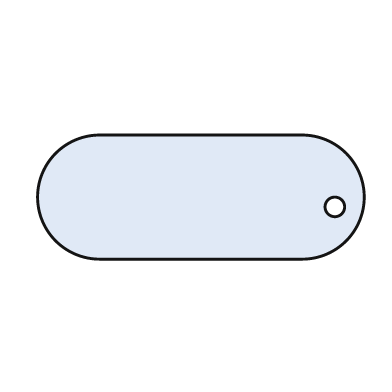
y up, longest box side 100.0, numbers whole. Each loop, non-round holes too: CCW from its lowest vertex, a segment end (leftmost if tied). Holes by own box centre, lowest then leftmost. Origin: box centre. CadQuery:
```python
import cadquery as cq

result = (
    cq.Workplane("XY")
    .moveTo(-31.0, -19.0)
    .lineTo(31.0, -19.0)
    .threePointArc((50.0, 0.0), (31.0, 19.0))
    .lineTo(-31.0, 19.0)
    .threePointArc((-50.0, 0.0), (-31.0, -19.0))
    .close()
    .moveTo(41.0, -3.0)
    .circle(3.0)
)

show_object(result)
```